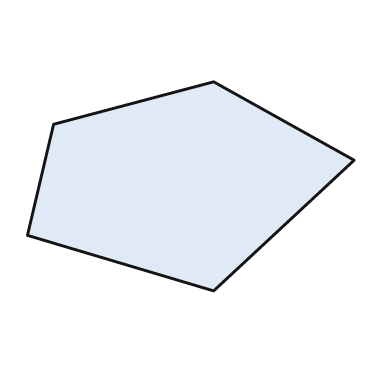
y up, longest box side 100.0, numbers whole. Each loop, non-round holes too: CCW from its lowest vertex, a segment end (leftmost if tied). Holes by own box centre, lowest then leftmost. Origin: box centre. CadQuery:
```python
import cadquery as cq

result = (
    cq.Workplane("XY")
    .moveTo(7.0, -32.0)
    .lineTo(50.0, 8.0)
    .lineTo(7.0, 32.0)
    .lineTo(-42.0, 19.0)
    .lineTo(-50.0, -15.0)
    .close()
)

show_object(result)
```